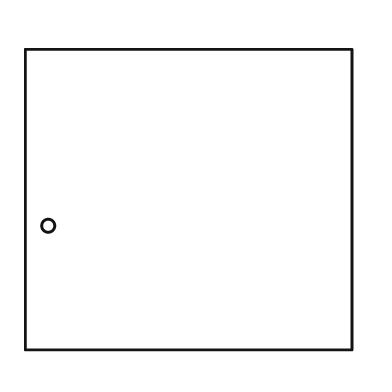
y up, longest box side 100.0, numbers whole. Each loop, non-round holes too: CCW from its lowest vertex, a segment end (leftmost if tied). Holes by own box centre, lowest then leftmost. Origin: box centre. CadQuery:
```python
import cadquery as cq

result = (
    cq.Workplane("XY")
    .moveTo(-50.0, -46.0)
    .lineTo(50.0, -46.0)
    .lineTo(50.0, 46.0)
    .lineTo(-50.0, 46.0)
    .close()
    .moveTo(-43.0, -8.0)
    .circle(2.0)
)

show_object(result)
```